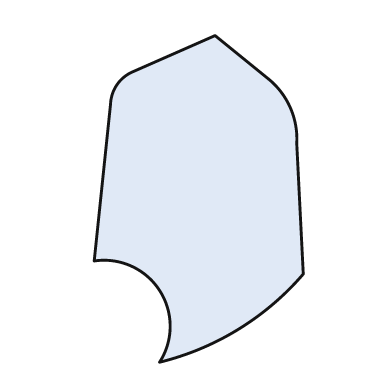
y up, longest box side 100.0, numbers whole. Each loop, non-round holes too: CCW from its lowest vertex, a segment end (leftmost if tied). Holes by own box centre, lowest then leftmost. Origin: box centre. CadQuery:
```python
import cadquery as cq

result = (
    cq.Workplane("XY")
    .moveTo(-12.0, -50.0)
    .threePointArc((12.0, -40.0), (32.0, -23.0))
    .lineTo(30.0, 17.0)
    .threePointArc((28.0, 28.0), (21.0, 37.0))
    .lineTo(5.0, 50.0)
    .lineTo(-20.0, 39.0)
    .threePointArc((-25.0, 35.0), (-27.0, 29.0))
    .lineTo(-32.0, -19.0)
    .threePointArc((-12.0, -28.0), (-12.0, -50.0))
    .close()
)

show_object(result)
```